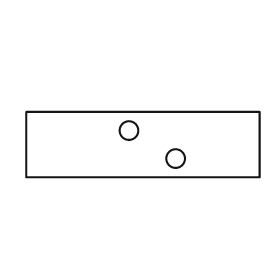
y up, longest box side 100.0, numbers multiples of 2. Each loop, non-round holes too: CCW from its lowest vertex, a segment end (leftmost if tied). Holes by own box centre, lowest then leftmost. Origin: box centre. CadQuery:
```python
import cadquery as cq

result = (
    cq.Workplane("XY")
    .moveTo(-50.0, -14.0)
    .lineTo(50.0, -14.0)
    .lineTo(50.0, 14.0)
    .lineTo(-50.0, 14.0)
    .close()
    .moveTo(14.0, -6.0)
    .circle(4.0)
    .moveTo(-6.0, 6.0)
    .circle(4.0)
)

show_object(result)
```